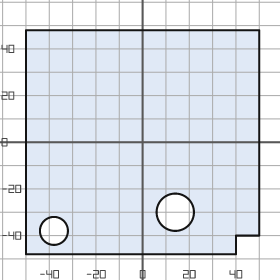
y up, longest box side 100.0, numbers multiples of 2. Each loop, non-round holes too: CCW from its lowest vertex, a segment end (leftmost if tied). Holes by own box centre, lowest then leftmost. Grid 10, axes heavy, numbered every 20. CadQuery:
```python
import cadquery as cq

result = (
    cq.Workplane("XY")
    .moveTo(-50.0, -48.0)
    .lineTo(40.0, -48.0)
    .lineTo(40.0, -40.0)
    .lineTo(50.0, -40.0)
    .lineTo(50.0, 48.0)
    .lineTo(-50.0, 48.0)
    .close()
    .moveTo(-38.0, -38.0)
    .circle(6.0)
    .moveTo(14.0, -30.0)
    .circle(8.0)
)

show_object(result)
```